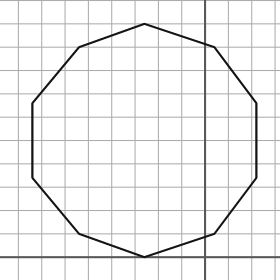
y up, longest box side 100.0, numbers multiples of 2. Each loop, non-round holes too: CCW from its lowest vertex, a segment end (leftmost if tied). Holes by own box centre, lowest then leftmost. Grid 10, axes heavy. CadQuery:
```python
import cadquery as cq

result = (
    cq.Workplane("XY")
    .moveTo(-26.0, 0.0)
    .lineTo(4.0, 10.0)
    .lineTo(22.0, 34.0)
    .lineTo(22.0, 66.0)
    .lineTo(4.0, 90.0)
    .lineTo(-26.0, 100.0)
    .lineTo(-54.0, 90.0)
    .lineTo(-74.0, 66.0)
    .lineTo(-74.0, 34.0)
    .lineTo(-54.0, 10.0)
    .close()
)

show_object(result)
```